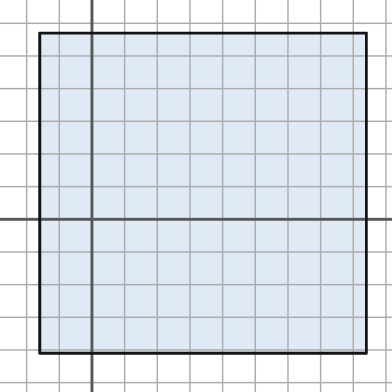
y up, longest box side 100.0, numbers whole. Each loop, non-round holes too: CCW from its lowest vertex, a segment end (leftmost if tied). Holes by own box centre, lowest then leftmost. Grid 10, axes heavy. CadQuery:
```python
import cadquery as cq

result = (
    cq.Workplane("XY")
    .moveTo(-16.0, -41.0)
    .lineTo(84.0, -41.0)
    .lineTo(84.0, 57.0)
    .lineTo(-16.0, 57.0)
    .close()
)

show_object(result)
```